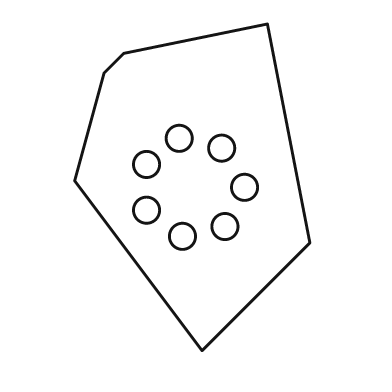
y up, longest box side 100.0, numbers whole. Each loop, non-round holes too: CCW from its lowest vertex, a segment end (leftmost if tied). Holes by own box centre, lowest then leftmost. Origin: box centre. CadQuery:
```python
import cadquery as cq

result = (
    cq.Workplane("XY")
    .moveTo(3.0, -50.0)
    .lineTo(36.0, -17.0)
    .lineTo(23.0, 50.0)
    .lineTo(-21.0, 41.0)
    .lineTo(-27.0, 35.0)
    .lineTo(-36.0, 2.0)
    .close()
    .moveTo(-3.0, -15.0)
    .circle(4.0)
    .moveTo(10.0, -12.0)
    .circle(4.0)
    .moveTo(-14.0, -7.0)
    .circle(4.0)
    .moveTo(16.0, 0.0)
    .circle(4.0)
    .moveTo(-14.0, 7.0)
    .circle(4.0)
    .moveTo(9.0, 12.0)
    .circle(4.0)
    .moveTo(-4.0, 15.0)
    .circle(4.0)
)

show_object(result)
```